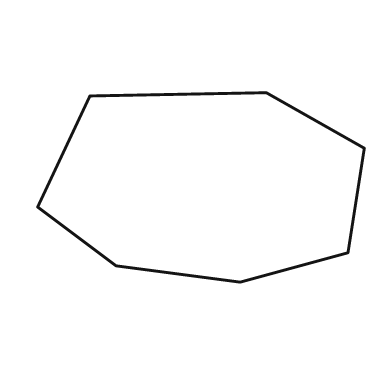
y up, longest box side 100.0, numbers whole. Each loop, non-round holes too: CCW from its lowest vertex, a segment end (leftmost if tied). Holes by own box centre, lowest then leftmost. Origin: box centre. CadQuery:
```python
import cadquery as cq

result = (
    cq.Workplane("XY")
    .moveTo(12.0, -29.0)
    .lineTo(45.0, -20.0)
    .lineTo(50.0, 12.0)
    .lineTo(20.0, 29.0)
    .lineTo(-34.0, 28.0)
    .lineTo(-50.0, -6.0)
    .lineTo(-26.0, -24.0)
    .close()
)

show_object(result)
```